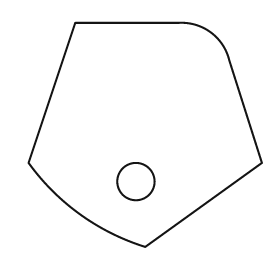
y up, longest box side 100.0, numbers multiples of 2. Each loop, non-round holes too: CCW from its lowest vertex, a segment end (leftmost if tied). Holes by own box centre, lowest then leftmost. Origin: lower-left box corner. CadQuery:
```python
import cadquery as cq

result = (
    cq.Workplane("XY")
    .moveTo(50.0, 0.0)
    .lineTo(100.0, 36.0)
    .lineTo(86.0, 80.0)
    .threePointArc((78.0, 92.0), (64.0, 96.0))
    .lineTo(20.0, 96.0)
    .lineTo(0.0, 36.0)
    .threePointArc((22.0, 14.0), (50.0, 0.0))
    .close()
    .moveTo(46.0, 28.0)
    .circle(8.0)
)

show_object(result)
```